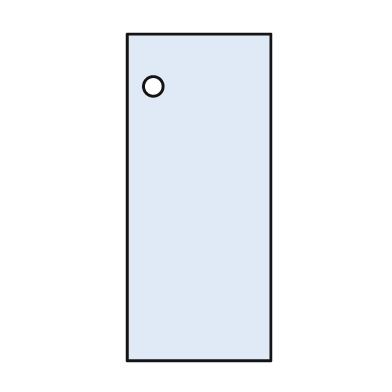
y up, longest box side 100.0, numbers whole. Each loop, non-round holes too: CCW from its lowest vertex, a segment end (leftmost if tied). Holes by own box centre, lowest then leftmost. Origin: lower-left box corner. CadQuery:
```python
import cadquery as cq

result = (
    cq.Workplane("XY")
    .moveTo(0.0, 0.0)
    .lineTo(44.0, 0.0)
    .lineTo(44.0, 100.0)
    .lineTo(0.0, 100.0)
    .close()
    .moveTo(8.0, 84.0)
    .circle(3.0)
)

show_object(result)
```